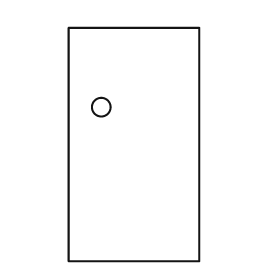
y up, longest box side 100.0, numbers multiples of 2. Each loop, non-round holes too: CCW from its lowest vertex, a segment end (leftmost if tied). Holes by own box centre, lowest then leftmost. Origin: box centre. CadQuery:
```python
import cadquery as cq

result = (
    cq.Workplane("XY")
    .moveTo(-28.0, -50.0)
    .lineTo(28.0, -50.0)
    .lineTo(28.0, 50.0)
    .lineTo(-28.0, 50.0)
    .close()
    .moveTo(-14.0, 16.0)
    .circle(4.0)
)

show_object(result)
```